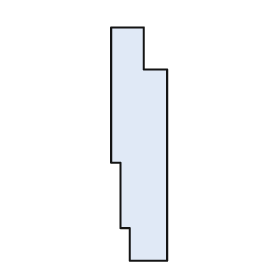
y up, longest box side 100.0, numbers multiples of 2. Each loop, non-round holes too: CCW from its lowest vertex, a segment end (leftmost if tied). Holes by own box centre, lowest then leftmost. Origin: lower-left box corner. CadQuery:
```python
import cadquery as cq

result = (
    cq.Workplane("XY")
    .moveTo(8.0, 0.0)
    .lineTo(24.0, 0.0)
    .lineTo(24.0, 82.0)
    .lineTo(14.0, 82.0)
    .lineTo(14.0, 100.0)
    .lineTo(0.0, 100.0)
    .lineTo(0.0, 42.0)
    .lineTo(4.0, 42.0)
    .lineTo(4.0, 14.0)
    .lineTo(8.0, 14.0)
    .close()
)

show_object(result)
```